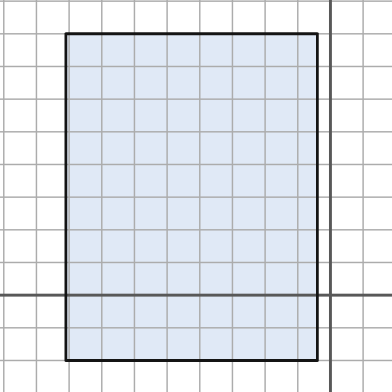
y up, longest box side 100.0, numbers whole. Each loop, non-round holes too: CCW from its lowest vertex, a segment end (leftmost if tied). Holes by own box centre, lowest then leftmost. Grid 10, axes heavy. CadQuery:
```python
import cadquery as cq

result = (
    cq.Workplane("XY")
    .moveTo(-81.0, -20.0)
    .lineTo(-4.0, -20.0)
    .lineTo(-4.0, 80.0)
    .lineTo(-81.0, 80.0)
    .close()
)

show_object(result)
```